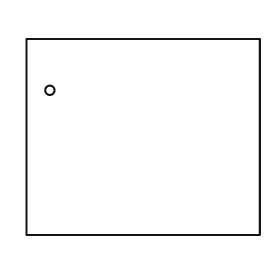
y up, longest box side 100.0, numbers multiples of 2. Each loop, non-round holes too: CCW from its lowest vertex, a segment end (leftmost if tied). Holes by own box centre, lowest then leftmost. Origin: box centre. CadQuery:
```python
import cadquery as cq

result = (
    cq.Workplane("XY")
    .moveTo(-50.0, -42.0)
    .lineTo(50.0, -42.0)
    .lineTo(50.0, 42.0)
    .lineTo(-50.0, 42.0)
    .close()
    .moveTo(-40.0, 20.0)
    .circle(2.0)
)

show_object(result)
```